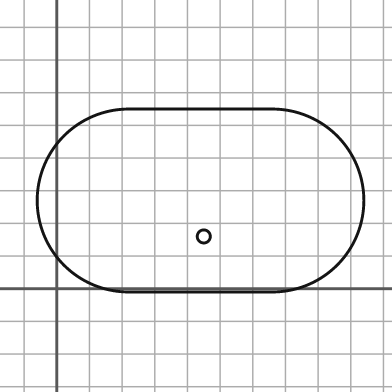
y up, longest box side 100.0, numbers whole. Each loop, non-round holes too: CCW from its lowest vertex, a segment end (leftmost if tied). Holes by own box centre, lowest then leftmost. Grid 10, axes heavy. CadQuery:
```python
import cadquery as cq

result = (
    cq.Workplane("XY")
    .moveTo(22.0, -1.0)
    .lineTo(66.0, -1.0)
    .threePointArc((94.0, 27.0), (66.0, 55.0))
    .lineTo(22.0, 55.0)
    .threePointArc((-6.0, 27.0), (22.0, -1.0))
    .close()
    .moveTo(45.0, 16.0)
    .circle(2.0)
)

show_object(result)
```